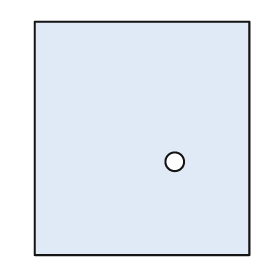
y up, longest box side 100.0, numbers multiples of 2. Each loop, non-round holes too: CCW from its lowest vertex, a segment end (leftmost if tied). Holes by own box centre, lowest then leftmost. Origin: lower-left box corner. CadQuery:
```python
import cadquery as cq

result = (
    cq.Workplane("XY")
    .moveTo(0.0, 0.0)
    .lineTo(92.0, 0.0)
    .lineTo(92.0, 100.0)
    .lineTo(0.0, 100.0)
    .close()
    .moveTo(60.0, 40.0)
    .circle(4.0)
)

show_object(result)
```